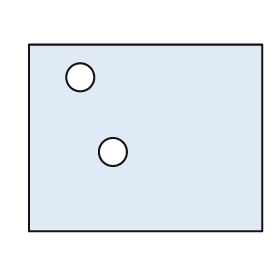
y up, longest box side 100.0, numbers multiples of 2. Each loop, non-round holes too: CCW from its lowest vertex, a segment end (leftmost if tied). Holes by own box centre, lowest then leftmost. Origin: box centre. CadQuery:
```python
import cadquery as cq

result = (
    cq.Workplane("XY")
    .moveTo(-50.0, -40.0)
    .lineTo(50.0, -40.0)
    .lineTo(50.0, 40.0)
    .lineTo(-50.0, 40.0)
    .close()
    .moveTo(-14.0, -6.0)
    .circle(6.0)
    .moveTo(-28.0, 26.0)
    .circle(6.0)
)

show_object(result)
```